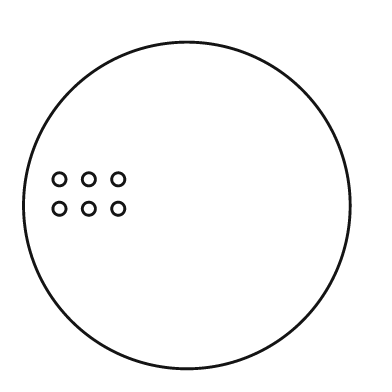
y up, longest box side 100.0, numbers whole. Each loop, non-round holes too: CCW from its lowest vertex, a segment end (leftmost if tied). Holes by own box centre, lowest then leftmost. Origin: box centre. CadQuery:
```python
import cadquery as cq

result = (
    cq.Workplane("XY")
    .moveTo(0.0, 0.0)
    .circle(50.0)
    .moveTo(-39.0, -1.0)
    .circle(2.0)
    .moveTo(-30.0, -1.0)
    .circle(2.0)
    .moveTo(-21.0, -1.0)
    .circle(2.0)
    .moveTo(-39.0, 8.0)
    .circle(2.0)
    .moveTo(-30.0, 8.0)
    .circle(2.0)
    .moveTo(-21.0, 8.0)
    .circle(2.0)
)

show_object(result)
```